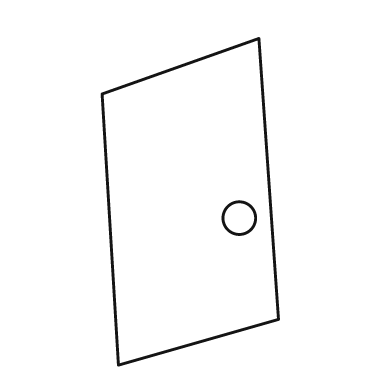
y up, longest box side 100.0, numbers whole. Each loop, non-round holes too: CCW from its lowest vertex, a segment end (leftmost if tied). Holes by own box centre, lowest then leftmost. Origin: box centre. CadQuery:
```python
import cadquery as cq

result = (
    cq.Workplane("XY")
    .moveTo(-22.0, -50.0)
    .lineTo(27.0, -36.0)
    .lineTo(21.0, 50.0)
    .lineTo(-27.0, 33.0)
    .close()
    .moveTo(15.0, -5.0)
    .circle(5.0)
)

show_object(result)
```